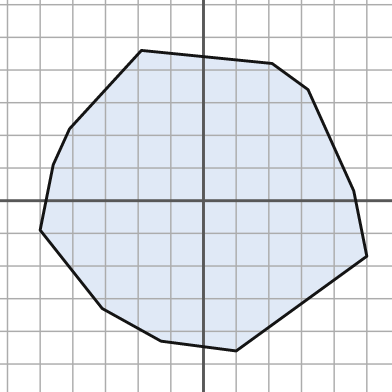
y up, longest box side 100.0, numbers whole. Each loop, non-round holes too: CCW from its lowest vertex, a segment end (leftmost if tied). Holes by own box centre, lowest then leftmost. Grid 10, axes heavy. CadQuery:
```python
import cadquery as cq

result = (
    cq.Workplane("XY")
    .moveTo(10.0, -46.0)
    .lineTo(50.0, -17.0)
    .lineTo(46.0, 3.0)
    .lineTo(32.0, 34.0)
    .lineTo(21.0, 42.0)
    .lineTo(-19.0, 46.0)
    .lineTo(-41.0, 22.0)
    .lineTo(-46.0, 11.0)
    .lineTo(-50.0, -9.0)
    .lineTo(-31.0, -33.0)
    .lineTo(-13.0, -43.0)
    .close()
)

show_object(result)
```